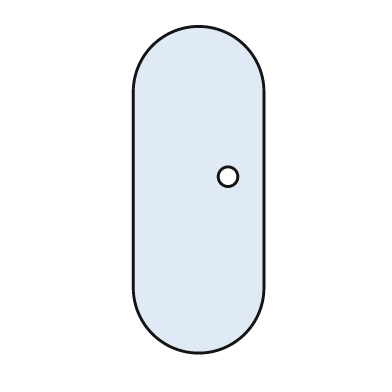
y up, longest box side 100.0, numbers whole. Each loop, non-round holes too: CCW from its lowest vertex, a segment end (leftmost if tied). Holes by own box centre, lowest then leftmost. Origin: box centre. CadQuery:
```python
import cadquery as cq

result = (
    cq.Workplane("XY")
    .moveTo(-20.0, -30.0)
    .threePointArc((0.0, -50.0), (20.0, -30.0))
    .lineTo(20.0, 30.0)
    .threePointArc((0.0, 50.0), (-20.0, 30.0))
    .close()
    .moveTo(9.0, 4.0)
    .circle(3.0)
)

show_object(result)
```